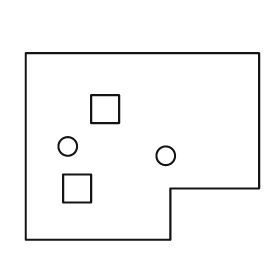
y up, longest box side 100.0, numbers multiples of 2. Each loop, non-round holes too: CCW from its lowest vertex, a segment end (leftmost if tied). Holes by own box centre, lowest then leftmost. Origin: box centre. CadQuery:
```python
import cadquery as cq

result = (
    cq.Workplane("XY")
    .moveTo(-50.0, -40.0)
    .lineTo(12.0, -40.0)
    .lineTo(12.0, -18.0)
    .lineTo(50.0, -18.0)
    .lineTo(50.0, 40.0)
    .lineTo(-50.0, 40.0)
    .close()
    .moveTo(-34.0, -24.0)
    .lineTo(-22.0, -24.0)
    .lineTo(-22.0, -12.0)
    .lineTo(-34.0, -12.0)
    .close()
    .moveTo(10.0, -4.0)
    .circle(4.0)
    .moveTo(-32.0, 0.0)
    .circle(4.0)
    .moveTo(-22.0, 10.0)
    .lineTo(-10.0, 10.0)
    .lineTo(-10.0, 22.0)
    .lineTo(-22.0, 22.0)
    .close()
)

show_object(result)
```